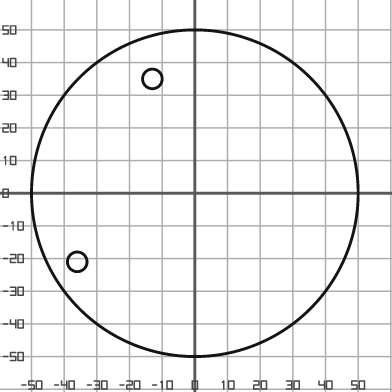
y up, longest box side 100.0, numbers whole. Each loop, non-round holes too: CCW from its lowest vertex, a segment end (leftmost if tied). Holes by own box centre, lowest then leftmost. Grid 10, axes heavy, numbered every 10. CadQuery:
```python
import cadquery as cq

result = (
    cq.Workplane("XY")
    .moveTo(0.0, 0.0)
    .circle(50.0)
    .moveTo(-36.0, -21.0)
    .circle(3.0)
    .moveTo(-13.0, 35.0)
    .circle(3.0)
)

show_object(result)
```